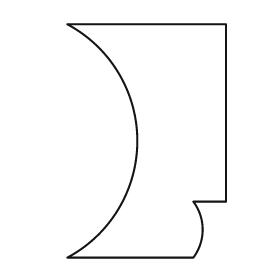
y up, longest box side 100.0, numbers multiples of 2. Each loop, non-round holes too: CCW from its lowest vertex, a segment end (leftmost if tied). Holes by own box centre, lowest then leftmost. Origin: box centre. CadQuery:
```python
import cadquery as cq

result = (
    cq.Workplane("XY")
    .moveTo(-34.0, -50.0)
    .lineTo(20.0, -50.0)
    .threePointArc((24.0, -38.0), (20.0, -26.0))
    .lineTo(34.0, -26.0)
    .lineTo(34.0, 50.0)
    .lineTo(-34.0, 50.0)
    .threePointArc((-4.0, 0.0), (-34.0, -50.0))
    .close()
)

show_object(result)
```